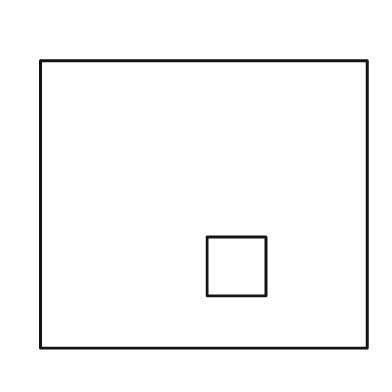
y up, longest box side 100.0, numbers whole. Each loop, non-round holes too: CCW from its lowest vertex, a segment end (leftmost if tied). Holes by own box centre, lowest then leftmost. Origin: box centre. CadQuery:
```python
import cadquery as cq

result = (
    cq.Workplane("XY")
    .moveTo(-50.0, -44.0)
    .lineTo(50.0, -44.0)
    .lineTo(50.0, 44.0)
    .lineTo(-50.0, 44.0)
    .close()
    .moveTo(1.0, -28.0)
    .lineTo(19.0, -28.0)
    .lineTo(19.0, -10.0)
    .lineTo(1.0, -10.0)
    .close()
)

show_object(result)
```